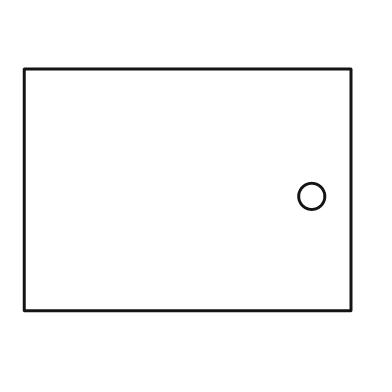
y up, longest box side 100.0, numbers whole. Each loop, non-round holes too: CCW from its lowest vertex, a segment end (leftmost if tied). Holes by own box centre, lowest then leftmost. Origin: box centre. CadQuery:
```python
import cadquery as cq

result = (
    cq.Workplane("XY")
    .moveTo(-50.0, -37.0)
    .lineTo(50.0, -37.0)
    .lineTo(50.0, 37.0)
    .lineTo(-50.0, 37.0)
    .close()
    .moveTo(38.0, -2.0)
    .circle(4.0)
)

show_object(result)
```